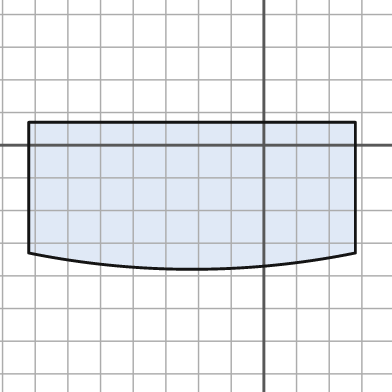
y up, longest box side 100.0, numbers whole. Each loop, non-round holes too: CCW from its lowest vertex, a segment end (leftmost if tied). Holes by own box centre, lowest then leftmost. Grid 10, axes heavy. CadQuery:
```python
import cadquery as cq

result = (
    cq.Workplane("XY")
    .moveTo(-72.0, -33.0)
    .threePointArc((-22.0, -38.0), (28.0, -33.0))
    .lineTo(28.0, 7.0)
    .lineTo(-72.0, 7.0)
    .close()
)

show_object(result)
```